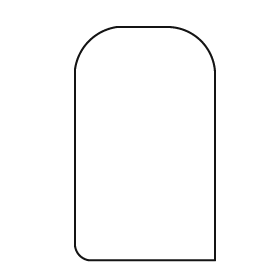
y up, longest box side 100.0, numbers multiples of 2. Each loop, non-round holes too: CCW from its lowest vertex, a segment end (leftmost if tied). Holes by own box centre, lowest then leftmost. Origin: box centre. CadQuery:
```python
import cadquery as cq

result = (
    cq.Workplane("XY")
    .moveTo(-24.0, -50.0)
    .lineTo(30.0, -50.0)
    .lineTo(30.0, 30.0)
    .threePointArc((24.0, 44.0), (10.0, 50.0))
    .lineTo(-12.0, 50.0)
    .threePointArc((-24.0, 44.0), (-30.0, 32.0))
    .lineTo(-30.0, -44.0)
    .threePointArc((-28.0, -48.0), (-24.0, -50.0))
    .close()
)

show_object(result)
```